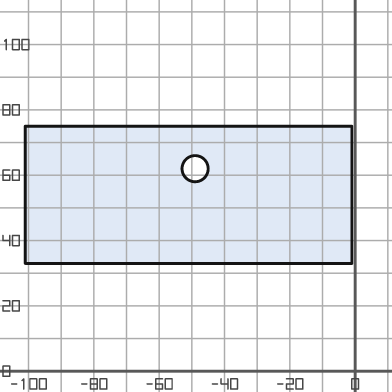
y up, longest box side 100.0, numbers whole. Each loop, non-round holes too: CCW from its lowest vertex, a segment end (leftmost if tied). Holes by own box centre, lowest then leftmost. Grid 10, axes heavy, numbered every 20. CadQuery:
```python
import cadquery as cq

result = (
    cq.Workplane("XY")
    .moveTo(-101.0, 33.0)
    .lineTo(-1.0, 33.0)
    .lineTo(-1.0, 75.0)
    .lineTo(-101.0, 75.0)
    .close()
    .moveTo(-49.0, 62.0)
    .circle(4.0)
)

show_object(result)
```